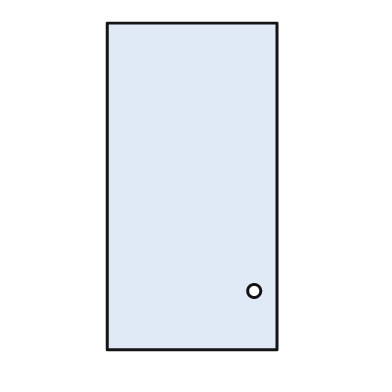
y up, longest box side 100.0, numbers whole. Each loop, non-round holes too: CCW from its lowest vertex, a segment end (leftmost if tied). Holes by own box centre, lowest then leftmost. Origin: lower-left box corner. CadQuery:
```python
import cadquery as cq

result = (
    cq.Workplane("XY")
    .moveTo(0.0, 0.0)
    .lineTo(52.0, 0.0)
    .lineTo(52.0, 100.0)
    .lineTo(0.0, 100.0)
    .close()
    .moveTo(45.0, 18.0)
    .circle(2.0)
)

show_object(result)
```